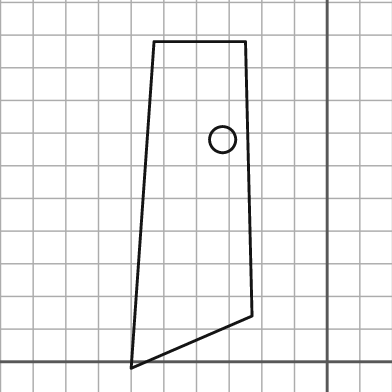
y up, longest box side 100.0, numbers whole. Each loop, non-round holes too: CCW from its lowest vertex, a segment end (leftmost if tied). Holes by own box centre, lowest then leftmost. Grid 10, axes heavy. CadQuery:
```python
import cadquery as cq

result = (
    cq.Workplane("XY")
    .moveTo(-60.0, -2.0)
    .lineTo(-23.0, 14.0)
    .lineTo(-25.0, 98.0)
    .lineTo(-53.0, 98.0)
    .close()
    .moveTo(-32.0, 68.0)
    .circle(4.0)
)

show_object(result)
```